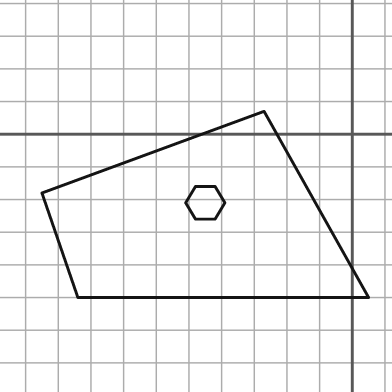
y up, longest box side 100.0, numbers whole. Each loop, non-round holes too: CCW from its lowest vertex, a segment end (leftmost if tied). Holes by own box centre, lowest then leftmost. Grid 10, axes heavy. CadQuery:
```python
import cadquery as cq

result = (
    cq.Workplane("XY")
    .moveTo(-84.0, -50.0)
    .lineTo(5.0, -50.0)
    .lineTo(-27.0, 7.0)
    .lineTo(-95.0, -18.0)
    .close()
    .moveTo(-48.0, -26.0)
    .lineTo(-42.0, -26.0)
    .lineTo(-39.0, -21.0)
    .lineTo(-42.0, -16.0)
    .lineTo(-48.0, -16.0)
    .lineTo(-51.0, -21.0)
    .close()
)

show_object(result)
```